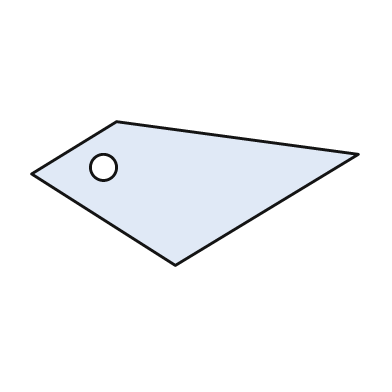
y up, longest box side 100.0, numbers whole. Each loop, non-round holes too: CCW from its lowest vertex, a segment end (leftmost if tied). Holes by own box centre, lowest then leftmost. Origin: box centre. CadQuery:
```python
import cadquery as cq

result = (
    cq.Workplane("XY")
    .moveTo(-6.0, -22.0)
    .lineTo(50.0, 12.0)
    .lineTo(-24.0, 22.0)
    .lineTo(-50.0, 6.0)
    .close()
    .moveTo(-28.0, 8.0)
    .circle(4.0)
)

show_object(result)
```